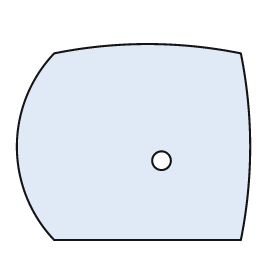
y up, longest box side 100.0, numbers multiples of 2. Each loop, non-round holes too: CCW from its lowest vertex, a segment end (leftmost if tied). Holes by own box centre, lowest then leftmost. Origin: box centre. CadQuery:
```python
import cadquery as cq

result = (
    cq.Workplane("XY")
    .moveTo(-34.0, -42.0)
    .lineTo(46.0, -42.0)
    .threePointArc((50.0, -2.0), (46.0, 38.0))
    .threePointArc((6.0, 42.0), (-34.0, 38.0))
    .threePointArc((-50.0, -2.0), (-34.0, -42.0))
    .close()
    .moveTo(12.0, -8.0)
    .circle(4.0)
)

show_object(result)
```